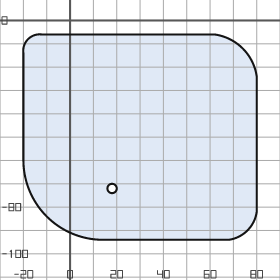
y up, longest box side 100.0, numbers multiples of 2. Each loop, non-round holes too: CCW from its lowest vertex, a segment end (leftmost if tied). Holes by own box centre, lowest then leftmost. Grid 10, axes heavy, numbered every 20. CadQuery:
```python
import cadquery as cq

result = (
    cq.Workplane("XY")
    .moveTo(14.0, -94.0)
    .lineTo(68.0, -94.0)
    .threePointArc((76.0, -90.0), (80.0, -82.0))
    .lineTo(80.0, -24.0)
    .threePointArc((74.0, -12.0), (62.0, -6.0))
    .lineTo(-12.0, -6.0)
    .threePointArc((-18.0, -8.0), (-20.0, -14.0))
    .lineTo(-20.0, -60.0)
    .threePointArc((-10.0, -84.0), (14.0, -94.0))
    .close()
    .moveTo(18.0, -72.0)
    .circle(2.0)
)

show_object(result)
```